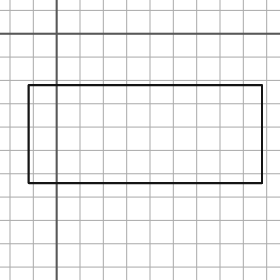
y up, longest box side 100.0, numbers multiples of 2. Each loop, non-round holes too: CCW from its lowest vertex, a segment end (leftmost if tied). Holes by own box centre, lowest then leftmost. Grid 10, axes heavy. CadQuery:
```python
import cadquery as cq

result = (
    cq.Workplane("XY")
    .moveTo(-12.0, -64.0)
    .lineTo(88.0, -64.0)
    .lineTo(88.0, -22.0)
    .lineTo(-12.0, -22.0)
    .close()
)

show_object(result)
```